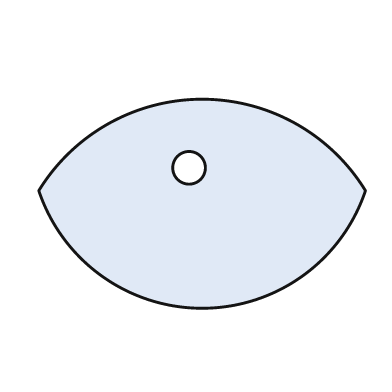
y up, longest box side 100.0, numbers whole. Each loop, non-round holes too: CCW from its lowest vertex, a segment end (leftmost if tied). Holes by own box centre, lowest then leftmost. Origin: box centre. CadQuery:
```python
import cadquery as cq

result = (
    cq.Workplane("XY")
    .moveTo(-50.0, 4.0)
    .threePointArc((0.0, -32.0), (50.0, 4.0))
    .threePointArc((0.0, 32.0), (-50.0, 4.0))
    .close()
    .moveTo(-4.0, 11.0)
    .circle(5.0)
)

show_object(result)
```